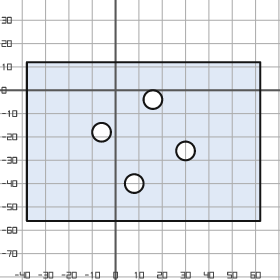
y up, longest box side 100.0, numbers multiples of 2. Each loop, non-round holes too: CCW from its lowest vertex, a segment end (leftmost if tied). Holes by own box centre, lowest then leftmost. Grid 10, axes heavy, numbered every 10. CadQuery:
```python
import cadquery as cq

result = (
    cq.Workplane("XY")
    .moveTo(-38.0, -56.0)
    .lineTo(62.0, -56.0)
    .lineTo(62.0, 12.0)
    .lineTo(-38.0, 12.0)
    .close()
    .moveTo(8.0, -40.0)
    .circle(4.0)
    .moveTo(30.0, -26.0)
    .circle(4.0)
    .moveTo(-6.0, -18.0)
    .circle(4.0)
    .moveTo(16.0, -4.0)
    .circle(4.0)
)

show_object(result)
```